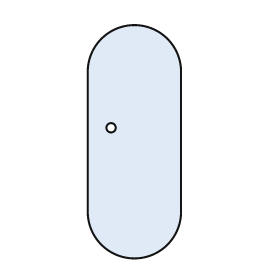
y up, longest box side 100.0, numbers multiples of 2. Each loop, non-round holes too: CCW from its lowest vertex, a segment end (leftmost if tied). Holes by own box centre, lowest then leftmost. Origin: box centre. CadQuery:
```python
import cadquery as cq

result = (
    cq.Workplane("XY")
    .moveTo(-20.0, -30.0)
    .threePointArc((0.0, -50.0), (20.0, -30.0))
    .lineTo(20.0, 30.0)
    .threePointArc((0.0, 50.0), (-20.0, 30.0))
    .close()
    .moveTo(-10.0, 6.0)
    .circle(2.0)
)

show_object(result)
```